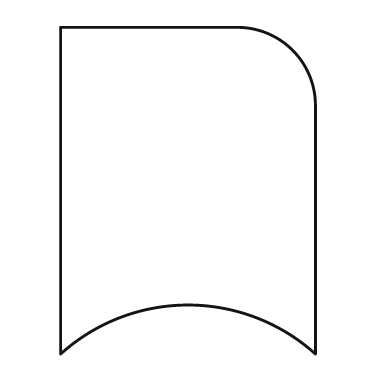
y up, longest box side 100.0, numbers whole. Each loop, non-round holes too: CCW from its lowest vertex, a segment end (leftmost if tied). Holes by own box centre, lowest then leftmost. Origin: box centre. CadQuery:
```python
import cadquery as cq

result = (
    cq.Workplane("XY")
    .moveTo(-39.0, -50.0)
    .threePointArc((0.0, -35.0), (39.0, -50.0))
    .lineTo(39.0, 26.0)
    .threePointArc((32.0, 43.0), (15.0, 50.0))
    .lineTo(-39.0, 50.0)
    .close()
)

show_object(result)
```